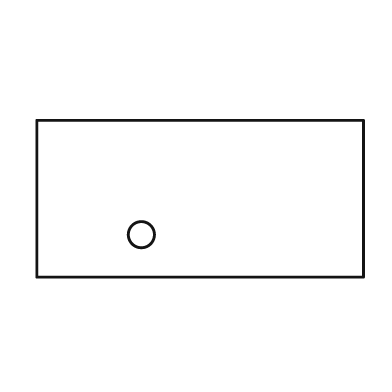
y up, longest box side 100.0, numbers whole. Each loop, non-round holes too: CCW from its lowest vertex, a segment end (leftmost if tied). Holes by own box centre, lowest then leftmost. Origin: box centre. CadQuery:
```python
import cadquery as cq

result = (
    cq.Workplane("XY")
    .moveTo(-50.0, -24.0)
    .lineTo(50.0, -24.0)
    .lineTo(50.0, 24.0)
    .lineTo(-50.0, 24.0)
    .close()
    .moveTo(-18.0, -11.0)
    .circle(4.0)
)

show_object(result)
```